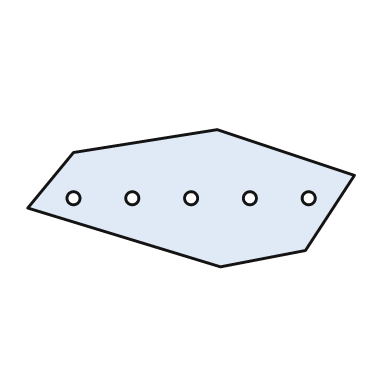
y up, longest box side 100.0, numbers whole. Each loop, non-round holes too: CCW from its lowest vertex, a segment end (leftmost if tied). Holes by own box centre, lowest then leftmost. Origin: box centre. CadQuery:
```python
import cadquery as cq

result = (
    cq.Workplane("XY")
    .moveTo(9.0, -21.0)
    .lineTo(35.0, -16.0)
    .lineTo(50.0, 7.0)
    .lineTo(8.0, 21.0)
    .lineTo(-36.0, 14.0)
    .lineTo(-50.0, -3.0)
    .close()
    .moveTo(-36.0, 0.0)
    .circle(2.0)
    .moveTo(-18.0, 0.0)
    .circle(2.0)
    .moveTo(0.0, 0.0)
    .circle(2.0)
    .moveTo(18.0, 0.0)
    .circle(2.0)
    .moveTo(36.0, 0.0)
    .circle(2.0)
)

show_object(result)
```